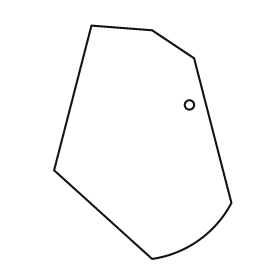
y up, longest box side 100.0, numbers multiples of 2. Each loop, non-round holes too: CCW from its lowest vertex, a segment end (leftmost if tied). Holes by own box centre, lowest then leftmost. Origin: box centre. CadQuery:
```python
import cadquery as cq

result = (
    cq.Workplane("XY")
    .moveTo(4.0, -50.0)
    .threePointArc((24.0, -42.0), (38.0, -26.0))
    .lineTo(22.0, 36.0)
    .lineTo(4.0, 48.0)
    .lineTo(-22.0, 50.0)
    .lineTo(-38.0, -12.0)
    .close()
    .moveTo(20.0, 16.0)
    .circle(2.0)
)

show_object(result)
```